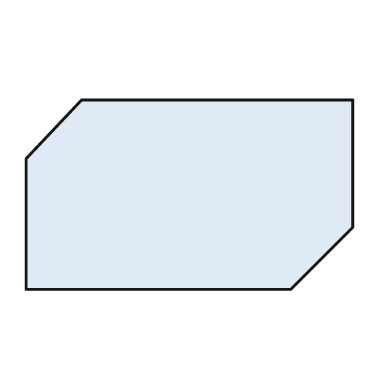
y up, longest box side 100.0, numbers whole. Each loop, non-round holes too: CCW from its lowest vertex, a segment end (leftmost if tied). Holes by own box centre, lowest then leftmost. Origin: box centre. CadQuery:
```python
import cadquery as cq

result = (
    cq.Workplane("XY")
    .moveTo(-50.0, -29.0)
    .lineTo(31.0, -29.0)
    .lineTo(50.0, -10.0)
    .lineTo(50.0, 29.0)
    .lineTo(-33.0, 29.0)
    .lineTo(-50.0, 11.0)
    .close()
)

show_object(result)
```